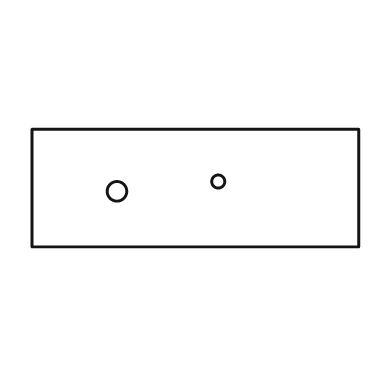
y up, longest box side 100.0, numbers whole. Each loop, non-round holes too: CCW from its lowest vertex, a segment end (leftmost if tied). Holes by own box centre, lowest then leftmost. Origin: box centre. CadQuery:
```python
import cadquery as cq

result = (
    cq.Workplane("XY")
    .moveTo(-50.0, -18.0)
    .lineTo(50.0, -18.0)
    .lineTo(50.0, 18.0)
    .lineTo(-50.0, 18.0)
    .close()
    .moveTo(-24.0, -1.0)
    .circle(3.0)
    .moveTo(7.0, 2.0)
    .circle(2.0)
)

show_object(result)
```